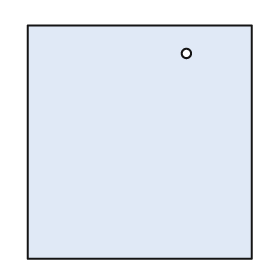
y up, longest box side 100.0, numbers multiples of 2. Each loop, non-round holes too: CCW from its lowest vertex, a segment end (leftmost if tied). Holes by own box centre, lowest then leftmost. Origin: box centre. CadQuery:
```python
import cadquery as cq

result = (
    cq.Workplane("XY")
    .moveTo(-48.0, -50.0)
    .lineTo(48.0, -50.0)
    .lineTo(48.0, 50.0)
    .lineTo(-48.0, 50.0)
    .close()
    .moveTo(20.0, 38.0)
    .circle(2.0)
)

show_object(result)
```